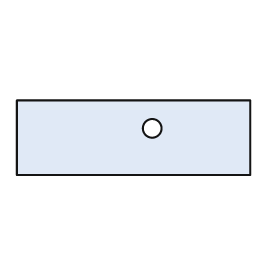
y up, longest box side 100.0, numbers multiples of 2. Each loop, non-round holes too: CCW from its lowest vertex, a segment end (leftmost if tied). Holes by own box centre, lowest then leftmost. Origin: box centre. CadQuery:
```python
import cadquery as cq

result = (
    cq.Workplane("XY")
    .moveTo(-50.0, -16.0)
    .lineTo(50.0, -16.0)
    .lineTo(50.0, 16.0)
    .lineTo(-50.0, 16.0)
    .close()
    .moveTo(8.0, 4.0)
    .circle(4.0)
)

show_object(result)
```